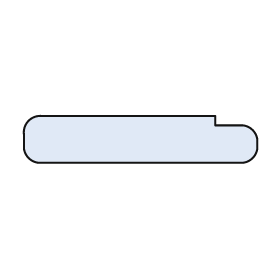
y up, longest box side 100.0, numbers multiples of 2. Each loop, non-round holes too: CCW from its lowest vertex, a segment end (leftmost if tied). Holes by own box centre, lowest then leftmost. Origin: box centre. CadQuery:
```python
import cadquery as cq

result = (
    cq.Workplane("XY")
    .moveTo(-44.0, -10.0)
    .lineTo(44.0, -10.0)
    .threePointArc((48.0, -8.0), (50.0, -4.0))
    .lineTo(50.0, 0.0)
    .threePointArc((48.0, 4.0), (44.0, 6.0))
    .lineTo(32.0, 6.0)
    .lineTo(32.0, 10.0)
    .lineTo(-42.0, 10.0)
    .threePointArc((-48.0, 8.0), (-50.0, 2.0))
    .lineTo(-50.0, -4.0)
    .threePointArc((-48.0, -8.0), (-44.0, -10.0))
    .close()
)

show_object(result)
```